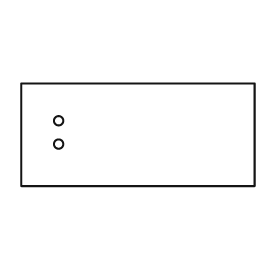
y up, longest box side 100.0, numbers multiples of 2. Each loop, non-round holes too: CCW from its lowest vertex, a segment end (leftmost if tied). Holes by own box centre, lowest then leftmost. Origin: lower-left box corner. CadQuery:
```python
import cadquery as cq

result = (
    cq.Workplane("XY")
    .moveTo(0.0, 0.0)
    .lineTo(100.0, 0.0)
    .lineTo(100.0, 44.0)
    .lineTo(0.0, 44.0)
    .close()
    .moveTo(16.0, 18.0)
    .circle(2.0)
    .moveTo(16.0, 28.0)
    .circle(2.0)
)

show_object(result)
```